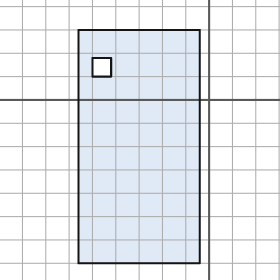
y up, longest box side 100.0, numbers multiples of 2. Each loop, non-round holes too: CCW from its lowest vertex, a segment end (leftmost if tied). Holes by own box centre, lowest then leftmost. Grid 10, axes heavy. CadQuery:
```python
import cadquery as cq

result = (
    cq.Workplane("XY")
    .moveTo(-56.0, -70.0)
    .lineTo(-4.0, -70.0)
    .lineTo(-4.0, 30.0)
    .lineTo(-56.0, 30.0)
    .close()
    .moveTo(-50.0, 10.0)
    .lineTo(-42.0, 10.0)
    .lineTo(-42.0, 18.0)
    .lineTo(-50.0, 18.0)
    .close()
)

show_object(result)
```